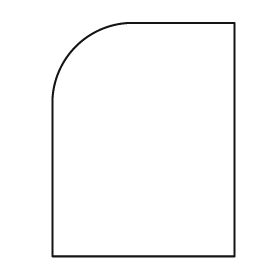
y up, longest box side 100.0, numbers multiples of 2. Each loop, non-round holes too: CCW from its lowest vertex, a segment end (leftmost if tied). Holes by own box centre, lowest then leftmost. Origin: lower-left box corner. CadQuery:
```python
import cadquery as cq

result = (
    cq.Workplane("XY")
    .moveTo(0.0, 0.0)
    .lineTo(78.0, 0.0)
    .lineTo(78.0, 100.0)
    .lineTo(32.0, 100.0)
    .threePointArc((10.0, 90.0), (0.0, 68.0))
    .close()
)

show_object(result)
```